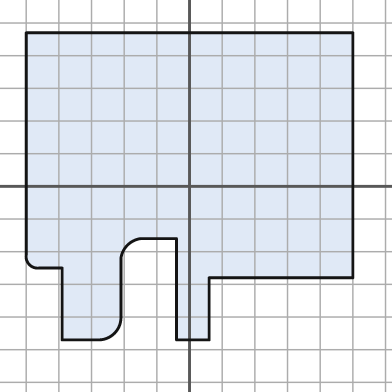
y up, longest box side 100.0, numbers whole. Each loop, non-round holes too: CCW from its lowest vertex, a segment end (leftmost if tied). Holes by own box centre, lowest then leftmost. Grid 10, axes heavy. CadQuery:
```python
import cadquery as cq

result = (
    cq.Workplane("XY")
    .moveTo(-39.0, -47.0)
    .lineTo(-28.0, -47.0)
    .threePointArc((-23.0, -45.0), (-21.0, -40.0))
    .lineTo(-21.0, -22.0)
    .threePointArc((-19.0, -18.0), (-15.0, -16.0))
    .lineTo(-4.0, -16.0)
    .lineTo(-4.0, -47.0)
    .lineTo(6.0, -47.0)
    .lineTo(6.0, -28.0)
    .lineTo(50.0, -28.0)
    .lineTo(50.0, 47.0)
    .lineTo(-50.0, 47.0)
    .lineTo(-50.0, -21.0)
    .threePointArc((-49.0, -24.0), (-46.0, -25.0))
    .lineTo(-39.0, -25.0)
    .close()
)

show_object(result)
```